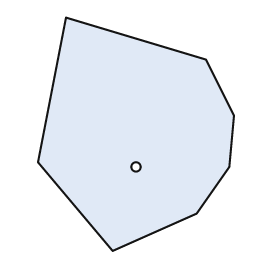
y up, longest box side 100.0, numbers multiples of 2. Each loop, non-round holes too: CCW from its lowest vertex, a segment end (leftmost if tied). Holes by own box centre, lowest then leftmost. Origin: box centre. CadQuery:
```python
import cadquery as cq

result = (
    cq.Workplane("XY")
    .moveTo(-10.0, -50.0)
    .lineTo(26.0, -34.0)
    .lineTo(40.0, -14.0)
    .lineTo(42.0, 8.0)
    .lineTo(30.0, 32.0)
    .lineTo(-30.0, 50.0)
    .lineTo(-42.0, -12.0)
    .close()
    .moveTo(0.0, -14.0)
    .circle(2.0)
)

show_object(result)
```